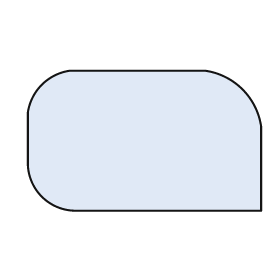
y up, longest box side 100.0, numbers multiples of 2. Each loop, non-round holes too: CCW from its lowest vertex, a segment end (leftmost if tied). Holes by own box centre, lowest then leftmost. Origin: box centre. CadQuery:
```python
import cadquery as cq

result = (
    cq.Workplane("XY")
    .moveTo(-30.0, -30.0)
    .lineTo(50.0, -30.0)
    .lineTo(50.0, 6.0)
    .threePointArc((42.0, 22.0), (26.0, 30.0))
    .lineTo(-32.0, 30.0)
    .threePointArc((-44.0, 24.0), (-50.0, 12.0))
    .lineTo(-50.0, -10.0)
    .threePointArc((-44.0, -24.0), (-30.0, -30.0))
    .close()
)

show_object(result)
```